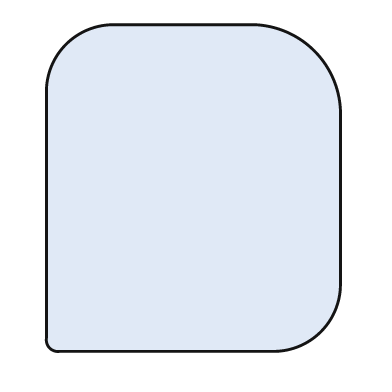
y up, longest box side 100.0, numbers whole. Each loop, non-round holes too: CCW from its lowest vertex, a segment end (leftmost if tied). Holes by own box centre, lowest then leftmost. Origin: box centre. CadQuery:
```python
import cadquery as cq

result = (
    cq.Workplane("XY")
    .moveTo(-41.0, -50.0)
    .lineTo(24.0, -50.0)
    .threePointArc((39.0, -44.0), (45.0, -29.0))
    .lineTo(45.0, 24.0)
    .threePointArc((37.0, 42.0), (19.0, 50.0))
    .lineTo(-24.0, 50.0)
    .threePointArc((-39.0, 44.0), (-45.0, 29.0))
    .lineTo(-45.0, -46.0)
    .threePointArc((-44.0, -49.0), (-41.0, -50.0))
    .close()
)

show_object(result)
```